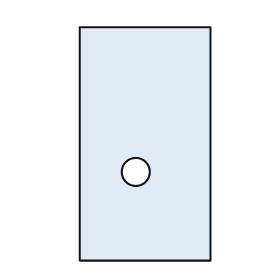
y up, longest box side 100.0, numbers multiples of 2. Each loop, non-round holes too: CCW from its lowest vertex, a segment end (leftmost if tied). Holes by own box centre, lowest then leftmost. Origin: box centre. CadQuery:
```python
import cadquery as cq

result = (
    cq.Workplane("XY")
    .moveTo(-28.0, -50.0)
    .lineTo(28.0, -50.0)
    .lineTo(28.0, 50.0)
    .lineTo(-28.0, 50.0)
    .close()
    .moveTo(-4.0, -12.0)
    .circle(6.0)
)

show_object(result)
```